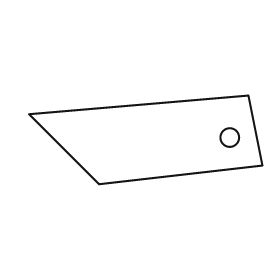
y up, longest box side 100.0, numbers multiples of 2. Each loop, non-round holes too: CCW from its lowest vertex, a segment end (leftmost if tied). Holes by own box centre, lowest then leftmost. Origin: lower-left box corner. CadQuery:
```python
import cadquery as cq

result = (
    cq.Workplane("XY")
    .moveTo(30.0, 0.0)
    .lineTo(100.0, 8.0)
    .lineTo(94.0, 38.0)
    .lineTo(0.0, 30.0)
    .close()
    .moveTo(86.0, 20.0)
    .circle(4.0)
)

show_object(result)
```